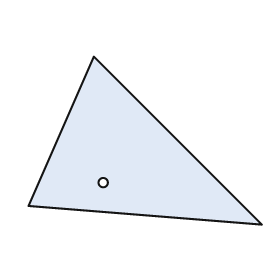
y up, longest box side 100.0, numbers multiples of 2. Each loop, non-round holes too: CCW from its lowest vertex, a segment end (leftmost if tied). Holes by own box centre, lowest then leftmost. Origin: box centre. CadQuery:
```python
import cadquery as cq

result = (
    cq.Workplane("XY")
    .moveTo(50.0, -36.0)
    .lineTo(-22.0, 36.0)
    .lineTo(-50.0, -28.0)
    .close()
    .moveTo(-18.0, -18.0)
    .circle(2.0)
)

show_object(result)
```